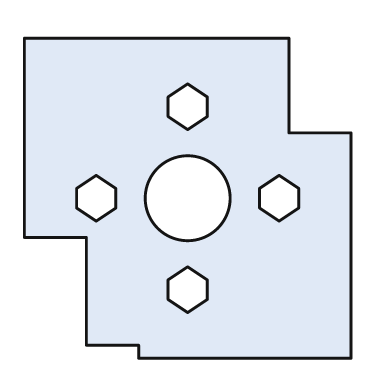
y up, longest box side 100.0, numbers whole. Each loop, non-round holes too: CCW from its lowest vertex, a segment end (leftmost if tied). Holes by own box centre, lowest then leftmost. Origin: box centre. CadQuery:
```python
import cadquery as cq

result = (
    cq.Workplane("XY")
    .moveTo(-15.0, -49.0)
    .lineTo(50.0, -49.0)
    .lineTo(50.0, 20.0)
    .lineTo(31.0, 20.0)
    .lineTo(31.0, 49.0)
    .lineTo(-50.0, 49.0)
    .lineTo(-50.0, -12.0)
    .lineTo(-31.0, -12.0)
    .lineTo(-31.0, -45.0)
    .lineTo(-15.0, -45.0)
    .close()
    .moveTo(0.0, -35.0)
    .lineTo(6.0, -31.0)
    .lineTo(6.0, -25.0)
    .lineTo(0.0, -21.0)
    .lineTo(-6.0, -25.0)
    .lineTo(-6.0, -31.0)
    .close()
    .moveTo(-28.0, -7.0)
    .lineTo(-22.0, -3.0)
    .lineTo(-22.0, 3.0)
    .lineTo(-28.0, 7.0)
    .lineTo(-34.0, 3.0)
    .lineTo(-34.0, -3.0)
    .close()
    .moveTo(0.0, 0.0)
    .circle(13.0)
    .moveTo(28.0, -7.0)
    .lineTo(34.0, -3.0)
    .lineTo(34.0, 3.0)
    .lineTo(28.0, 7.0)
    .lineTo(22.0, 3.0)
    .lineTo(22.0, -3.0)
    .close()
    .moveTo(0.0, 21.0)
    .lineTo(6.0, 25.0)
    .lineTo(6.0, 31.0)
    .lineTo(0.0, 35.0)
    .lineTo(-6.0, 31.0)
    .lineTo(-6.0, 25.0)
    .close()
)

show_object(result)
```